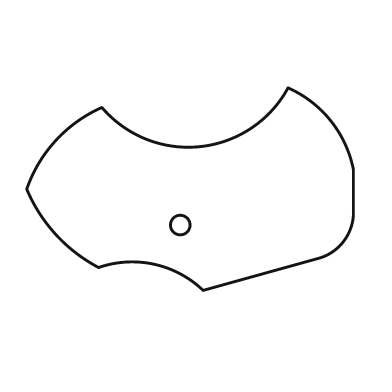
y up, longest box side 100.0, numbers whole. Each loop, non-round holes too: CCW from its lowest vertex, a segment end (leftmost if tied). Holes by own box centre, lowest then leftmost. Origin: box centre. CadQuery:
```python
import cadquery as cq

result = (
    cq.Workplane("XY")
    .moveTo(4.0, -31.0)
    .lineTo(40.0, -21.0)
    .threePointArc((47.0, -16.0), (50.0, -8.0))
    .lineTo(50.0, 6.0)
    .threePointArc((43.0, 21.0), (30.0, 31.0))
    .threePointArc((3.0, 13.0), (-27.0, 25.0))
    .threePointArc((-41.0, 15.0), (-50.0, 0.0))
    .threePointArc((-41.0, -14.0), (-28.0, -24.0))
    .threePointArc((-11.0, -23.0), (4.0, -31.0))
    .close()
    .moveTo(-3.0, -11.0)
    .circle(3.0)
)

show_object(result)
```